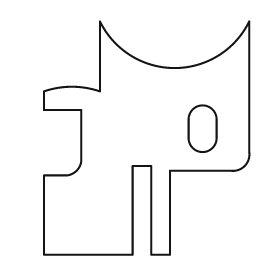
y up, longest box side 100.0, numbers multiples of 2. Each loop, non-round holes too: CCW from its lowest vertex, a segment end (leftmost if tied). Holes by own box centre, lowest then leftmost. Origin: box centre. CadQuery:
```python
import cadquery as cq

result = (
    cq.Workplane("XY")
    .moveTo(-44.0, -50.0)
    .lineTo(-6.0, -50.0)
    .lineTo(-6.0, -12.0)
    .lineTo(2.0, -12.0)
    .lineTo(2.0, -50.0)
    .lineTo(10.0, -50.0)
    .lineTo(10.0, -14.0)
    .lineTo(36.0, -14.0)
    .threePointArc((42.0, -12.0), (44.0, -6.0))
    .lineTo(44.0, 50.0)
    .threePointArc((12.0, 30.0), (-20.0, 50.0))
    .lineTo(-20.0, 20.0)
    .threePointArc((-32.0, 22.0), (-44.0, 20.0))
    .lineTo(-44.0, 12.0)
    .lineTo(-28.0, 12.0)
    .lineTo(-28.0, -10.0)
    .threePointArc((-30.0, -14.0), (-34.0, -16.0))
    .lineTo(-44.0, -16.0)
    .close()
    .moveTo(18.0, 0.0)
    .threePointArc((24.0, -6.0), (30.0, 0.0))
    .lineTo(30.0, 8.0)
    .threePointArc((24.0, 14.0), (18.0, 8.0))
    .close()
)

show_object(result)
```